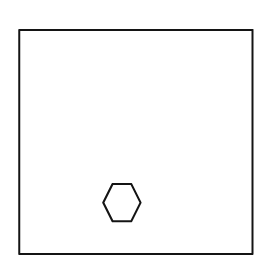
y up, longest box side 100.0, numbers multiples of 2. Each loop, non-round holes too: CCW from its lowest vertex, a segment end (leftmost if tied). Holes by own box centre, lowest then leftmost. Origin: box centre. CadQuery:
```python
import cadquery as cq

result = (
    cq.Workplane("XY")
    .moveTo(-50.0, -48.0)
    .lineTo(50.0, -48.0)
    .lineTo(50.0, 48.0)
    .lineTo(-50.0, 48.0)
    .close()
    .moveTo(-10.0, -34.0)
    .lineTo(-2.0, -34.0)
    .lineTo(2.0, -26.0)
    .lineTo(-2.0, -18.0)
    .lineTo(-10.0, -18.0)
    .lineTo(-14.0, -26.0)
    .close()
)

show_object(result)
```